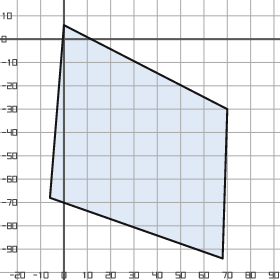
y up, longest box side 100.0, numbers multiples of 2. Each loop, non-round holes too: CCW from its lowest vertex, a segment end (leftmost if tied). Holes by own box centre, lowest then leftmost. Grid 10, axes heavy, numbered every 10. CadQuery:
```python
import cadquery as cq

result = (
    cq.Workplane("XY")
    .moveTo(68.0, -94.0)
    .lineTo(70.0, -30.0)
    .lineTo(0.0, 6.0)
    .lineTo(-6.0, -68.0)
    .close()
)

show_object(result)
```